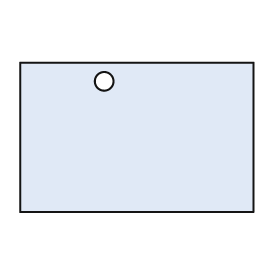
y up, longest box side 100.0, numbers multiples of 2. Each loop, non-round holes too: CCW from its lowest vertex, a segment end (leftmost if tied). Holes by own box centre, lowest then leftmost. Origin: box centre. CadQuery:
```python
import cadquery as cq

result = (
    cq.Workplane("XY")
    .moveTo(-50.0, -32.0)
    .lineTo(50.0, -32.0)
    .lineTo(50.0, 32.0)
    .lineTo(-50.0, 32.0)
    .close()
    .moveTo(-14.0, 24.0)
    .circle(4.0)
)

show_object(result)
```